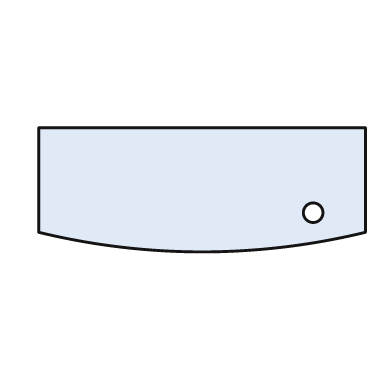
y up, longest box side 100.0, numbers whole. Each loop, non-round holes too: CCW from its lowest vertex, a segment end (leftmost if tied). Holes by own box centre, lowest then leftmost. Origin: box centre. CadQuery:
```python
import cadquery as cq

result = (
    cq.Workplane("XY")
    .moveTo(-50.0, -13.0)
    .threePointArc((0.0, -19.0), (50.0, -13.0))
    .lineTo(50.0, 19.0)
    .lineTo(-50.0, 19.0)
    .close()
    .moveTo(34.0, -7.0)
    .circle(3.0)
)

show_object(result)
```